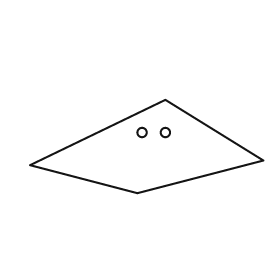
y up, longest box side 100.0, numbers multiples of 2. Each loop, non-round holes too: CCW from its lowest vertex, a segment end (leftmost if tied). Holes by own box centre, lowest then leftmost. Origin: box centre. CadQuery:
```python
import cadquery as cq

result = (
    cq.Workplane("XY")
    .moveTo(-4.0, -20.0)
    .lineTo(50.0, -6.0)
    .lineTo(8.0, 20.0)
    .lineTo(-50.0, -8.0)
    .close()
    .moveTo(-2.0, 6.0)
    .circle(2.0)
    .moveTo(8.0, 6.0)
    .circle(2.0)
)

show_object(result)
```